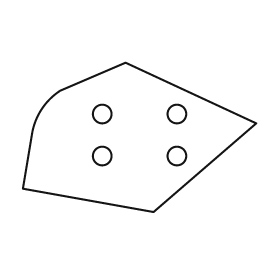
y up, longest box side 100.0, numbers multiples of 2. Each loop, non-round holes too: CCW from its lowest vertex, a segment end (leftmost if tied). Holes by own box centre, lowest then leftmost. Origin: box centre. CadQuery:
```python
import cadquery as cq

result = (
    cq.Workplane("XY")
    .moveTo(6.0, -32.0)
    .lineTo(50.0, 6.0)
    .lineTo(-6.0, 32.0)
    .lineTo(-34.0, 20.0)
    .threePointArc((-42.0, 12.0), (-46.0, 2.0))
    .lineTo(-50.0, -22.0)
    .close()
    .moveTo(-16.0, -8.0)
    .circle(4.0)
    .moveTo(16.0, -8.0)
    .circle(4.0)
    .moveTo(-16.0, 10.0)
    .circle(4.0)
    .moveTo(16.0, 10.0)
    .circle(4.0)
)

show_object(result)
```